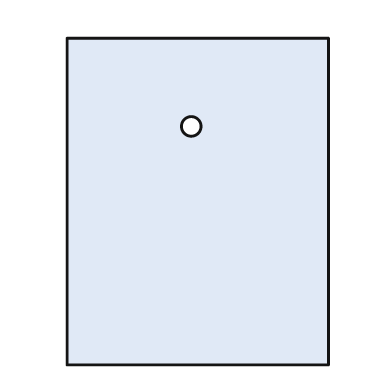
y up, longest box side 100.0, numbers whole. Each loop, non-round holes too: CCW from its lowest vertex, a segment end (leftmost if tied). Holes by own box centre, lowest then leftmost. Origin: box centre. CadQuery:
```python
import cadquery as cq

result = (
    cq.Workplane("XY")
    .moveTo(-40.0, -50.0)
    .lineTo(40.0, -50.0)
    .lineTo(40.0, 50.0)
    .lineTo(-40.0, 50.0)
    .close()
    .moveTo(-2.0, 23.0)
    .circle(3.0)
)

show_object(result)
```